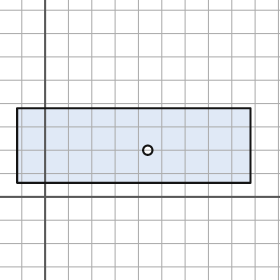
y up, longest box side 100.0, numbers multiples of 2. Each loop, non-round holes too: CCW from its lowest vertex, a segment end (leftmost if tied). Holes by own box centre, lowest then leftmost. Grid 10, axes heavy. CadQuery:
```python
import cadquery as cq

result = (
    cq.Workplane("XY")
    .moveTo(-12.0, 6.0)
    .lineTo(88.0, 6.0)
    .lineTo(88.0, 38.0)
    .lineTo(-12.0, 38.0)
    .close()
    .moveTo(44.0, 20.0)
    .circle(2.0)
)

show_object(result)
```